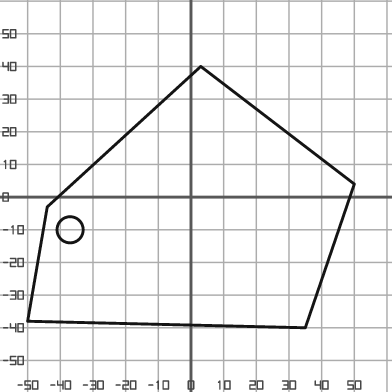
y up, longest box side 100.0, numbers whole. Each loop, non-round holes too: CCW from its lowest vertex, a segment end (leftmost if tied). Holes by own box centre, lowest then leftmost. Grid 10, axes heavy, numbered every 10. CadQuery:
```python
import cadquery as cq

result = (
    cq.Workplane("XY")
    .moveTo(35.0, -40.0)
    .lineTo(50.0, 4.0)
    .lineTo(3.0, 40.0)
    .lineTo(-44.0, -3.0)
    .lineTo(-50.0, -38.0)
    .close()
    .moveTo(-37.0, -10.0)
    .circle(4.0)
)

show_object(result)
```